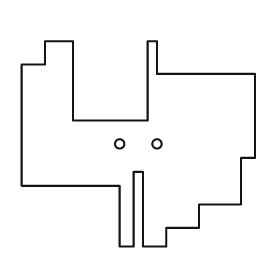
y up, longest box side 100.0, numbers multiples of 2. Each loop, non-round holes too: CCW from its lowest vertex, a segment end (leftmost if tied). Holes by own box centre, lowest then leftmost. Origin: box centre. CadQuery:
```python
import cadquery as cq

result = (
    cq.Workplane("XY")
    .moveTo(-8.0, -44.0)
    .lineTo(-2.0, -44.0)
    .lineTo(-2.0, -12.0)
    .lineTo(2.0, -12.0)
    .lineTo(2.0, -44.0)
    .lineTo(12.0, -44.0)
    .lineTo(12.0, -36.0)
    .lineTo(26.0, -36.0)
    .lineTo(26.0, -26.0)
    .lineTo(44.0, -26.0)
    .lineTo(44.0, -6.0)
    .lineTo(50.0, -6.0)
    .lineTo(50.0, 30.0)
    .lineTo(8.0, 30.0)
    .lineTo(8.0, 44.0)
    .lineTo(4.0, 44.0)
    .lineTo(4.0, 10.0)
    .lineTo(-28.0, 10.0)
    .lineTo(-28.0, 44.0)
    .lineTo(-40.0, 44.0)
    .lineTo(-40.0, 34.0)
    .lineTo(-50.0, 34.0)
    .lineTo(-50.0, -18.0)
    .lineTo(-8.0, -18.0)
    .close()
    .moveTo(-8.0, 0.0)
    .circle(2.0)
    .moveTo(8.0, 0.0)
    .circle(2.0)
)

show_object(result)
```